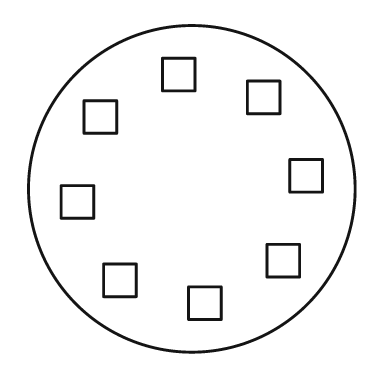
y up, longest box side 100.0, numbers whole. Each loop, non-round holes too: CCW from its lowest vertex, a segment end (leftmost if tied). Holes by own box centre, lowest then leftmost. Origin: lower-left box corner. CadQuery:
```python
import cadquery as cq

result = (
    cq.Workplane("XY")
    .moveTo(50.0, 50.0)
    .circle(50.0)
    .moveTo(49.0, 10.0)
    .lineTo(59.0, 10.0)
    .lineTo(59.0, 20.0)
    .lineTo(49.0, 20.0)
    .close()
    .moveTo(23.0, 17.0)
    .lineTo(33.0, 17.0)
    .lineTo(33.0, 27.0)
    .lineTo(23.0, 27.0)
    .close()
    .moveTo(73.0, 23.0)
    .lineTo(83.0, 23.0)
    .lineTo(83.0, 33.0)
    .lineTo(73.0, 33.0)
    .close()
    .moveTo(10.0, 41.0)
    .lineTo(20.0, 41.0)
    .lineTo(20.0, 51.0)
    .lineTo(10.0, 51.0)
    .close()
    .moveTo(80.0, 49.0)
    .lineTo(90.0, 49.0)
    .lineTo(90.0, 59.0)
    .lineTo(80.0, 59.0)
    .close()
    .moveTo(17.0, 67.0)
    .lineTo(27.0, 67.0)
    .lineTo(27.0, 77.0)
    .lineTo(17.0, 77.0)
    .close()
    .moveTo(67.0, 73.0)
    .lineTo(77.0, 73.0)
    .lineTo(77.0, 83.0)
    .lineTo(67.0, 83.0)
    .close()
    .moveTo(41.0, 80.0)
    .lineTo(51.0, 80.0)
    .lineTo(51.0, 90.0)
    .lineTo(41.0, 90.0)
    .close()
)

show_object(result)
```